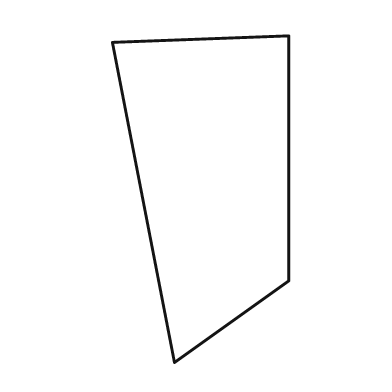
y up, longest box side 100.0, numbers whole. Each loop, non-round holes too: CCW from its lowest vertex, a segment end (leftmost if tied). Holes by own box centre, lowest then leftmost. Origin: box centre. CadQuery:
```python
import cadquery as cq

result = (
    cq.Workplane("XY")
    .moveTo(-8.0, -50.0)
    .lineTo(27.0, -25.0)
    .lineTo(27.0, 50.0)
    .lineTo(-27.0, 48.0)
    .close()
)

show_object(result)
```